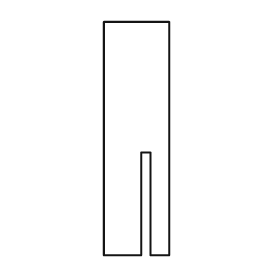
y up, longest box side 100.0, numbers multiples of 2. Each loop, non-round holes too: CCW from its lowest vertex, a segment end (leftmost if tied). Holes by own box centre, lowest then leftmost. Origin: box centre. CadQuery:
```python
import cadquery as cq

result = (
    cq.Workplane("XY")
    .moveTo(-14.0, -50.0)
    .lineTo(2.0, -50.0)
    .lineTo(2.0, -6.0)
    .lineTo(6.0, -6.0)
    .lineTo(6.0, -50.0)
    .lineTo(14.0, -50.0)
    .lineTo(14.0, 50.0)
    .lineTo(-14.0, 50.0)
    .close()
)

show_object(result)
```